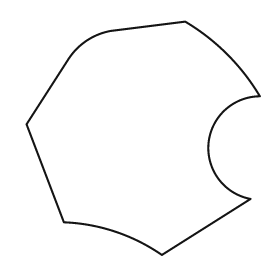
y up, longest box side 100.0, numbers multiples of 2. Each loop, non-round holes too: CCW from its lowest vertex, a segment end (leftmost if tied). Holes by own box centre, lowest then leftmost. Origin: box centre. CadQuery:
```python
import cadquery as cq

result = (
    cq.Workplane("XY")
    .moveTo(8.0, -50.0)
    .lineTo(46.0, -26.0)
    .threePointArc((28.0, -2.0), (50.0, 18.0))
    .threePointArc((36.0, 36.0), (18.0, 50.0))
    .lineTo(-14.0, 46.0)
    .threePointArc((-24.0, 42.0), (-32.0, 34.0))
    .lineTo(-50.0, 6.0)
    .lineTo(-34.0, -36.0)
    .threePointArc((-12.0, -40.0), (8.0, -50.0))
    .close()
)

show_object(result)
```